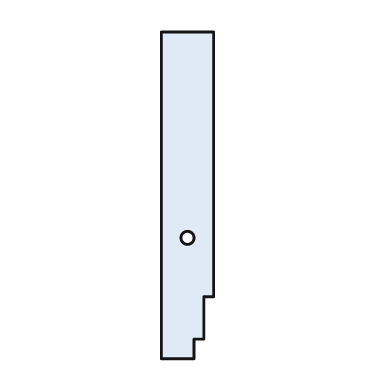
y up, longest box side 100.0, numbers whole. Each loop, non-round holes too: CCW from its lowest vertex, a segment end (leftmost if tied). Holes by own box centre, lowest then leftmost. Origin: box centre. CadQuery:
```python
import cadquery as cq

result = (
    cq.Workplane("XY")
    .moveTo(-8.0, -50.0)
    .lineTo(2.0, -50.0)
    .lineTo(2.0, -44.0)
    .lineTo(5.0, -44.0)
    .lineTo(5.0, -31.0)
    .lineTo(8.0, -31.0)
    .lineTo(8.0, 50.0)
    .lineTo(-8.0, 50.0)
    .close()
    .moveTo(0.0, -13.0)
    .circle(2.0)
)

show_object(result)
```